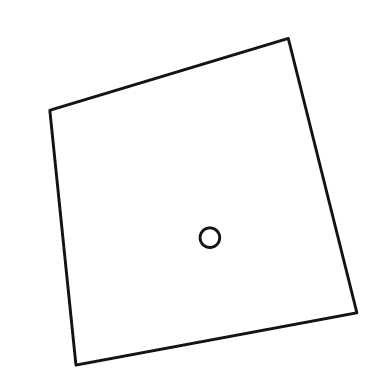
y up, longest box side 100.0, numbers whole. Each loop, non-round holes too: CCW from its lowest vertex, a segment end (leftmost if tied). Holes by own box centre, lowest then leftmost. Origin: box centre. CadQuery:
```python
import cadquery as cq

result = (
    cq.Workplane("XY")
    .moveTo(-39.0, -50.0)
    .lineTo(47.0, -34.0)
    .lineTo(26.0, 50.0)
    .lineTo(-47.0, 28.0)
    .close()
    .moveTo(2.0, -11.0)
    .circle(3.0)
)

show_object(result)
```